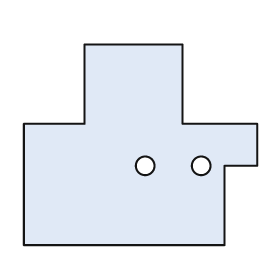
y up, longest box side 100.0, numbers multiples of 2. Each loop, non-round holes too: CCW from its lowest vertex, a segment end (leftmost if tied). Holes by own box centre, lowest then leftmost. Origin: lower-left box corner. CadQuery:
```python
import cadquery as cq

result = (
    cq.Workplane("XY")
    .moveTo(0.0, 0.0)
    .lineTo(86.0, 0.0)
    .lineTo(86.0, 34.0)
    .lineTo(100.0, 34.0)
    .lineTo(100.0, 52.0)
    .lineTo(68.0, 52.0)
    .lineTo(68.0, 86.0)
    .lineTo(26.0, 86.0)
    .lineTo(26.0, 52.0)
    .lineTo(0.0, 52.0)
    .close()
    .moveTo(52.0, 34.0)
    .circle(4.0)
    .moveTo(76.0, 34.0)
    .circle(4.0)
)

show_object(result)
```